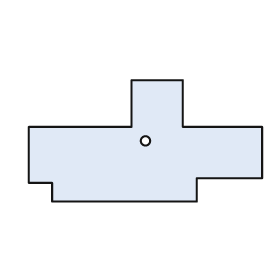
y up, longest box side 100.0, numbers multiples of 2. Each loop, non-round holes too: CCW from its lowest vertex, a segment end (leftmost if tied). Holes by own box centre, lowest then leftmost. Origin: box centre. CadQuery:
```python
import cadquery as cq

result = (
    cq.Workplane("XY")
    .moveTo(-40.0, -26.0)
    .lineTo(22.0, -26.0)
    .lineTo(22.0, -16.0)
    .lineTo(50.0, -16.0)
    .lineTo(50.0, 6.0)
    .lineTo(16.0, 6.0)
    .lineTo(16.0, 26.0)
    .lineTo(-6.0, 26.0)
    .lineTo(-6.0, 6.0)
    .lineTo(-50.0, 6.0)
    .lineTo(-50.0, -18.0)
    .lineTo(-40.0, -18.0)
    .close()
    .moveTo(0.0, 0.0)
    .circle(2.0)
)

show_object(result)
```